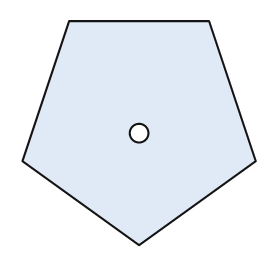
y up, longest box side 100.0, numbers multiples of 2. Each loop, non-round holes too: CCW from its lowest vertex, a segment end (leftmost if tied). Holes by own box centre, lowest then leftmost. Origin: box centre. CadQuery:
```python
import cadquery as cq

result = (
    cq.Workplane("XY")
    .moveTo(0.0, -48.0)
    .lineTo(50.0, -12.0)
    .lineTo(30.0, 48.0)
    .lineTo(-30.0, 48.0)
    .lineTo(-50.0, -12.0)
    .close()
    .moveTo(0.0, 0.0)
    .circle(4.0)
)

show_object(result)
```